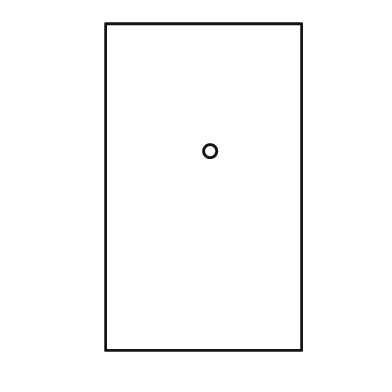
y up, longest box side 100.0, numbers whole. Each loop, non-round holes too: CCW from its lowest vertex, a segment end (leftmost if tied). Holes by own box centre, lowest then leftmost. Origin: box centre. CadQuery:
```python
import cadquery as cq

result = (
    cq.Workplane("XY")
    .moveTo(-30.0, -50.0)
    .lineTo(30.0, -50.0)
    .lineTo(30.0, 50.0)
    .lineTo(-30.0, 50.0)
    .close()
    .moveTo(2.0, 11.0)
    .circle(2.0)
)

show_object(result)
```